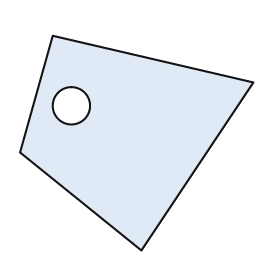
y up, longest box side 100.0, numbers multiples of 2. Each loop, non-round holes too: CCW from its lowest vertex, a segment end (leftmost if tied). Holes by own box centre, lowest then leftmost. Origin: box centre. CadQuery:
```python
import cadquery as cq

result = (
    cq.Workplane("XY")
    .moveTo(2.0, -46.0)
    .lineTo(50.0, 26.0)
    .lineTo(-36.0, 46.0)
    .lineTo(-50.0, -4.0)
    .close()
    .moveTo(-28.0, 16.0)
    .circle(8.0)
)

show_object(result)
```